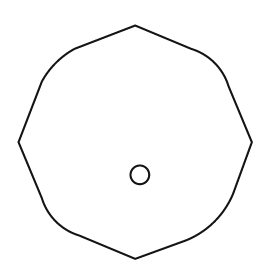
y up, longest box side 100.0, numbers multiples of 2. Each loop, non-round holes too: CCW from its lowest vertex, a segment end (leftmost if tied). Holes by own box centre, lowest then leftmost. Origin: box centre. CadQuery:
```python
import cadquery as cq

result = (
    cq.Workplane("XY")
    .moveTo(0.0, -50.0)
    .lineTo(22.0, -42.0)
    .threePointArc((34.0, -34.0), (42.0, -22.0))
    .lineTo(50.0, 0.0)
    .lineTo(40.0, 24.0)
    .threePointArc((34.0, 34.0), (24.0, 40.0))
    .lineTo(0.0, 50.0)
    .lineTo(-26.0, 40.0)
    .threePointArc((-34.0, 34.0), (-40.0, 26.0))
    .lineTo(-50.0, 0.0)
    .lineTo(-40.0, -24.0)
    .threePointArc((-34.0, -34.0), (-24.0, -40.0))
    .close()
    .moveTo(2.0, -14.0)
    .circle(4.0)
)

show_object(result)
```